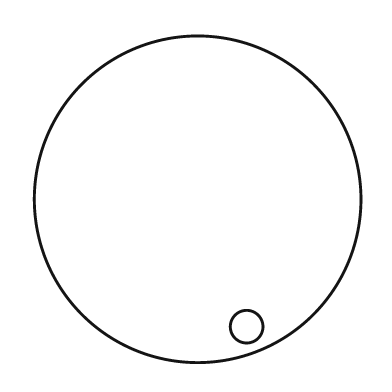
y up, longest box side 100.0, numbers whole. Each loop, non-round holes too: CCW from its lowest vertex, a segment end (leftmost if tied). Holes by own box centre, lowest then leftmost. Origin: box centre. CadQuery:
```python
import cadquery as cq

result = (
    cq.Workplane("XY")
    .moveTo(0.0, 0.0)
    .circle(50.0)
    .moveTo(15.0, -39.0)
    .circle(5.0)
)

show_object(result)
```